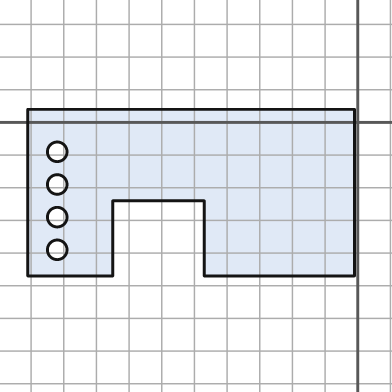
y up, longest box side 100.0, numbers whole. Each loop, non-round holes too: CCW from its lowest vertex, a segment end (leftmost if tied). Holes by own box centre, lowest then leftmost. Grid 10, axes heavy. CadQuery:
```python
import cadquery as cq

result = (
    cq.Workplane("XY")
    .moveTo(-101.0, -47.0)
    .lineTo(-75.0, -47.0)
    .lineTo(-75.0, -24.0)
    .lineTo(-47.0, -24.0)
    .lineTo(-47.0, -47.0)
    .lineTo(-1.0, -47.0)
    .lineTo(-1.0, 4.0)
    .lineTo(-101.0, 4.0)
    .close()
    .moveTo(-92.0, -39.0)
    .circle(3.0)
    .moveTo(-92.0, -29.0)
    .circle(3.0)
    .moveTo(-92.0, -19.0)
    .circle(3.0)
    .moveTo(-92.0, -9.0)
    .circle(3.0)
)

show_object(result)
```